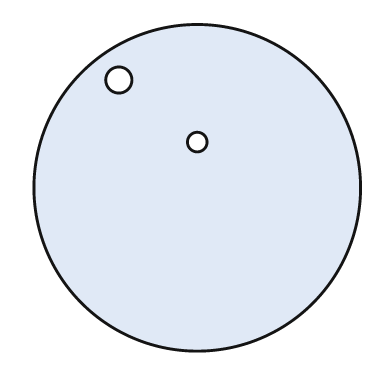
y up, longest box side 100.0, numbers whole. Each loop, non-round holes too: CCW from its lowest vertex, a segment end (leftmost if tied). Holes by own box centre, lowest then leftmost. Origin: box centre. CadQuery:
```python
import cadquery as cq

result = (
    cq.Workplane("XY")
    .moveTo(0.0, 0.0)
    .circle(50.0)
    .moveTo(0.0, 14.0)
    .circle(3.0)
    .moveTo(-24.0, 33.0)
    .circle(4.0)
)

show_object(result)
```